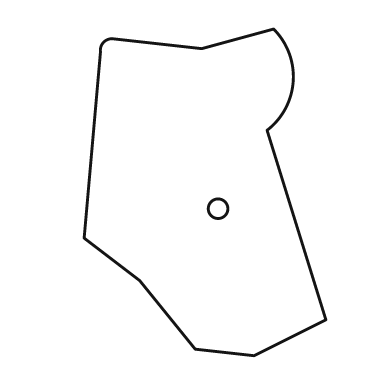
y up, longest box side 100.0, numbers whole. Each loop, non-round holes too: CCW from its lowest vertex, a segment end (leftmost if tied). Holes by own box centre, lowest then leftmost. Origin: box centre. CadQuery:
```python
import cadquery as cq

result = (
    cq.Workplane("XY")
    .moveTo(15.0, -50.0)
    .lineTo(37.0, -39.0)
    .lineTo(19.0, 19.0)
    .threePointArc((27.0, 34.0), (21.0, 50.0))
    .lineTo(-1.0, 44.0)
    .lineTo(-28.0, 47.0)
    .threePointArc((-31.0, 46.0), (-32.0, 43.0))
    .lineTo(-37.0, -14.0)
    .lineTo(-20.0, -27.0)
    .lineTo(-3.0, -48.0)
    .close()
    .moveTo(4.0, -5.0)
    .circle(3.0)
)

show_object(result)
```